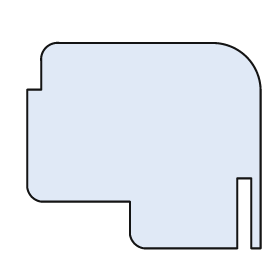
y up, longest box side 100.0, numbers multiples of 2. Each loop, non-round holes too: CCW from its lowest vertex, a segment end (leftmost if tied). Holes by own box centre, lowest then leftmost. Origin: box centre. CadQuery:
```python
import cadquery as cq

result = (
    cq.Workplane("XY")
    .moveTo(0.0, -44.0)
    .lineTo(40.0, -44.0)
    .lineTo(40.0, -14.0)
    .lineTo(46.0, -14.0)
    .lineTo(46.0, -44.0)
    .lineTo(50.0, -44.0)
    .lineTo(50.0, 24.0)
    .threePointArc((44.0, 38.0), (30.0, 44.0))
    .lineTo(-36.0, 44.0)
    .threePointArc((-42.0, 42.0), (-44.0, 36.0))
    .lineTo(-44.0, 24.0)
    .lineTo(-50.0, 24.0)
    .lineTo(-50.0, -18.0)
    .threePointArc((-48.0, -22.0), (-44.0, -24.0))
    .lineTo(-6.0, -24.0)
    .lineTo(-6.0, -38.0)
    .threePointArc((-4.0, -42.0), (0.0, -44.0))
    .close()
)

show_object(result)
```